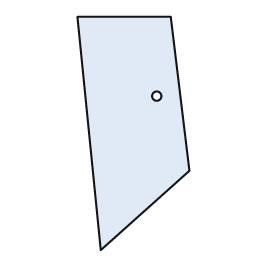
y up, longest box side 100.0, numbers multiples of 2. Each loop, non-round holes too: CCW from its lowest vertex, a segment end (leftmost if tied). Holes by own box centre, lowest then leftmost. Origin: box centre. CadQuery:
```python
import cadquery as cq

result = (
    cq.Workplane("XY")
    .moveTo(-14.0, -50.0)
    .lineTo(24.0, -16.0)
    .lineTo(16.0, 50.0)
    .lineTo(-24.0, 50.0)
    .close()
    .moveTo(10.0, 16.0)
    .circle(2.0)
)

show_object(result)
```